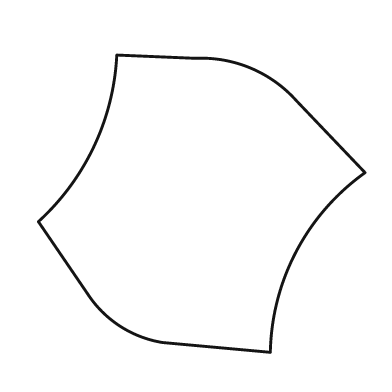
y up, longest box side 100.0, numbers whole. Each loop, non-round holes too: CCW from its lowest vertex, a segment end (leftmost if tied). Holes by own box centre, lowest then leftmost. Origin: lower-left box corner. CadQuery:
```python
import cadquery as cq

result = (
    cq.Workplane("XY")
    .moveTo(71.0, 0.0)
    .threePointArc((79.0, 31.0), (100.0, 55.0))
    .lineTo(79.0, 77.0)
    .threePointArc((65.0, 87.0), (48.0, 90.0))
    .lineTo(24.0, 91.0)
    .threePointArc((17.0, 63.0), (0.0, 40.0))
    .lineTo(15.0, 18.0)
    .threePointArc((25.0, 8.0), (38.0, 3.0))
    .close()
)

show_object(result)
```